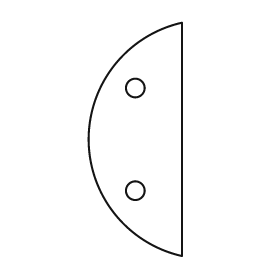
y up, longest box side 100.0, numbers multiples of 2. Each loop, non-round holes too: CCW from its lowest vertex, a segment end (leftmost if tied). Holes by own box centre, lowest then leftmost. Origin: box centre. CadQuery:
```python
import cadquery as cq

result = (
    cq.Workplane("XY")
    .moveTo(20.0, -50.0)
    .lineTo(20.0, 50.0)
    .threePointArc((-20.0, 0.0), (20.0, -50.0))
    .close()
    .moveTo(0.0, -22.0)
    .circle(4.0)
    .moveTo(0.0, 22.0)
    .circle(4.0)
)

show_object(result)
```